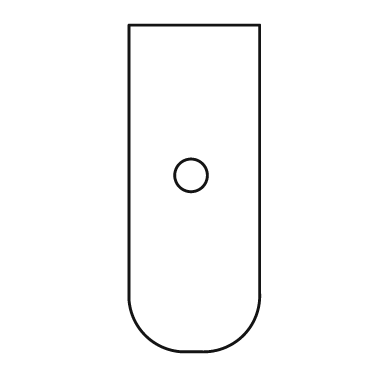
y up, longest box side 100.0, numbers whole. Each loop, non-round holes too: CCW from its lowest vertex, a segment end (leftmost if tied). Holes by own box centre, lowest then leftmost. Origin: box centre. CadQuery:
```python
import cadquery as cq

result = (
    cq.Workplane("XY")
    .moveTo(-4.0, -50.0)
    .lineTo(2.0, -50.0)
    .threePointArc((15.0, -45.0), (20.0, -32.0))
    .lineTo(20.0, 50.0)
    .lineTo(-20.0, 50.0)
    .lineTo(-20.0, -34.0)
    .threePointArc((-15.0, -45.0), (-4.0, -50.0))
    .close()
    .moveTo(-1.0, 4.0)
    .circle(5.0)
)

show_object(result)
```